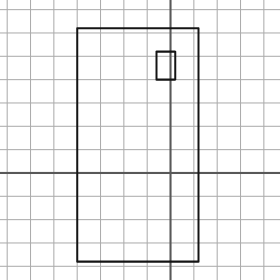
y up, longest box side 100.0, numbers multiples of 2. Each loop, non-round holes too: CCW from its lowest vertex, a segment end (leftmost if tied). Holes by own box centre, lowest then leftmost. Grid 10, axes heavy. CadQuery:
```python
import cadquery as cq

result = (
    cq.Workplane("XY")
    .moveTo(-40.0, -38.0)
    .lineTo(12.0, -38.0)
    .lineTo(12.0, 62.0)
    .lineTo(-40.0, 62.0)
    .close()
    .moveTo(-6.0, 40.0)
    .lineTo(2.0, 40.0)
    .lineTo(2.0, 52.0)
    .lineTo(-6.0, 52.0)
    .close()
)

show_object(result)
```